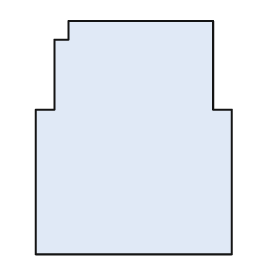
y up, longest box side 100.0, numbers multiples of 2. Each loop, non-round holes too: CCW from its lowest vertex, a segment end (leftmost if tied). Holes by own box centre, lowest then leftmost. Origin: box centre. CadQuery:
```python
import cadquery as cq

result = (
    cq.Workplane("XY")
    .moveTo(-42.0, -50.0)
    .lineTo(42.0, -50.0)
    .lineTo(42.0, 12.0)
    .lineTo(34.0, 12.0)
    .lineTo(34.0, 50.0)
    .lineTo(-28.0, 50.0)
    .lineTo(-28.0, 42.0)
    .lineTo(-34.0, 42.0)
    .lineTo(-34.0, 12.0)
    .lineTo(-42.0, 12.0)
    .close()
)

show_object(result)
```